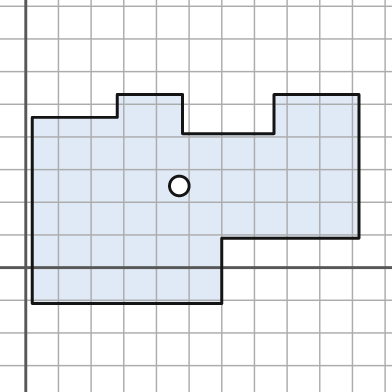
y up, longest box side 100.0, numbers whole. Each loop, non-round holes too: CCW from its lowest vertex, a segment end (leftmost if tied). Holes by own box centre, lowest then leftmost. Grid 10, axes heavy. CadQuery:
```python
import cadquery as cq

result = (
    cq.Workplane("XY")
    .moveTo(2.0, -11.0)
    .lineTo(60.0, -11.0)
    .lineTo(60.0, 9.0)
    .lineTo(102.0, 9.0)
    .lineTo(102.0, 53.0)
    .lineTo(76.0, 53.0)
    .lineTo(76.0, 41.0)
    .lineTo(48.0, 41.0)
    .lineTo(48.0, 53.0)
    .lineTo(28.0, 53.0)
    .lineTo(28.0, 46.0)
    .lineTo(2.0, 46.0)
    .close()
    .moveTo(47.0, 25.0)
    .circle(3.0)
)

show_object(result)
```